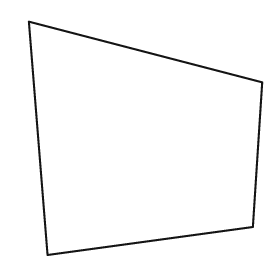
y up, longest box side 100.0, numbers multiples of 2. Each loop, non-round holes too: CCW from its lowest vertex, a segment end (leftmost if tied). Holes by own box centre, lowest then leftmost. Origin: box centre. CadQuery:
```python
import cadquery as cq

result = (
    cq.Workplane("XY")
    .moveTo(-42.0, -50.0)
    .lineTo(46.0, -38.0)
    .lineTo(50.0, 24.0)
    .lineTo(-50.0, 50.0)
    .close()
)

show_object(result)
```